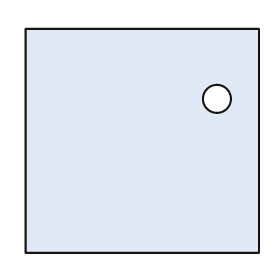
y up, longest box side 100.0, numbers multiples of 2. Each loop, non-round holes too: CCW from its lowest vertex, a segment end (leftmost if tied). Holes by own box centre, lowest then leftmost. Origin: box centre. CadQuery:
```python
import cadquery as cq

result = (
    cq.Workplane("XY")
    .moveTo(-50.0, -48.0)
    .lineTo(50.0, -48.0)
    .lineTo(50.0, 48.0)
    .lineTo(-50.0, 48.0)
    .close()
    .moveTo(32.0, 18.0)
    .circle(6.0)
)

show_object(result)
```